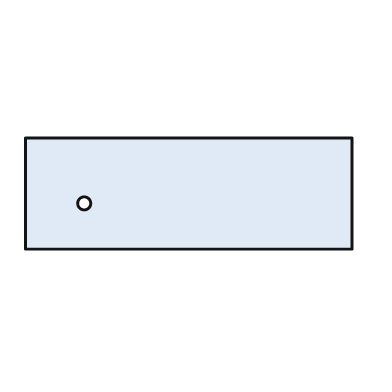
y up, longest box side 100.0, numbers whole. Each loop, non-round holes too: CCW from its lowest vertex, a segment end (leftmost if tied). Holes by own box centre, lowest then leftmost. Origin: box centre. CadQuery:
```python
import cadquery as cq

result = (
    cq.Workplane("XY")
    .moveTo(-50.0, -17.0)
    .lineTo(50.0, -17.0)
    .lineTo(50.0, 17.0)
    .lineTo(-50.0, 17.0)
    .close()
    .moveTo(-32.0, -3.0)
    .circle(2.0)
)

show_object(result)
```